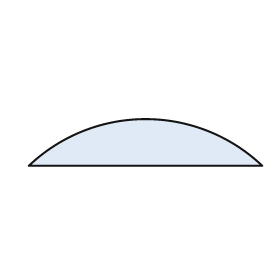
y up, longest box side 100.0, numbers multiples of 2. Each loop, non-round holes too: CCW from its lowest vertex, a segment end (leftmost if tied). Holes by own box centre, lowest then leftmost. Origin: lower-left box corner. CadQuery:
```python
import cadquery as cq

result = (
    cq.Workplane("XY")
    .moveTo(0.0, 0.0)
    .lineTo(100.0, 0.0)
    .threePointArc((50.0, 20.0), (0.0, 0.0))
    .close()
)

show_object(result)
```